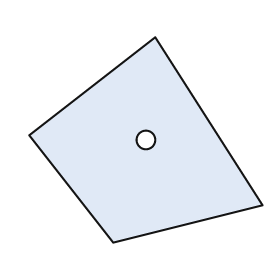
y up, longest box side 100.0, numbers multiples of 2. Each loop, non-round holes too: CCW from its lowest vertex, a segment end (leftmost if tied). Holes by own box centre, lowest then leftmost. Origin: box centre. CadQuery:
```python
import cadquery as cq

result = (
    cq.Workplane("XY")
    .moveTo(-14.0, -44.0)
    .lineTo(50.0, -28.0)
    .lineTo(4.0, 44.0)
    .lineTo(-50.0, 2.0)
    .close()
    .moveTo(0.0, 0.0)
    .circle(4.0)
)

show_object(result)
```